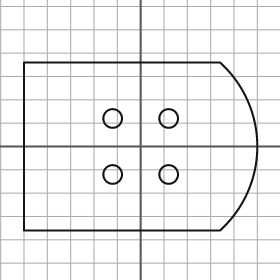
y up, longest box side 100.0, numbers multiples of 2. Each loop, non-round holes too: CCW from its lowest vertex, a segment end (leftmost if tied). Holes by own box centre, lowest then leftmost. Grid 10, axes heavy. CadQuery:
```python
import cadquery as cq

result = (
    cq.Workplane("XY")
    .moveTo(-50.0, -36.0)
    .lineTo(34.0, -36.0)
    .threePointArc((50.0, 0.0), (34.0, 36.0))
    .lineTo(-50.0, 36.0)
    .close()
    .moveTo(-12.0, -12.0)
    .circle(4.0)
    .moveTo(12.0, -12.0)
    .circle(4.0)
    .moveTo(-12.0, 12.0)
    .circle(4.0)
    .moveTo(12.0, 12.0)
    .circle(4.0)
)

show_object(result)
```